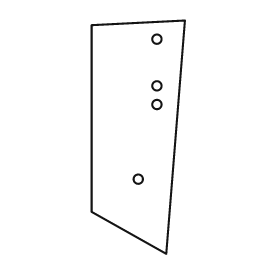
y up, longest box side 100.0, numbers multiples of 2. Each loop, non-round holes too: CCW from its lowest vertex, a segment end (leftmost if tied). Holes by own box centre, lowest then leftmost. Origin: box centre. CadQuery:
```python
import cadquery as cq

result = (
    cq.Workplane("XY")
    .moveTo(12.0, -50.0)
    .lineTo(20.0, 50.0)
    .lineTo(-20.0, 48.0)
    .lineTo(-20.0, -32.0)
    .close()
    .moveTo(0.0, -18.0)
    .circle(2.0)
    .moveTo(8.0, 14.0)
    .circle(2.0)
    .moveTo(8.0, 22.0)
    .circle(2.0)
    .moveTo(8.0, 42.0)
    .circle(2.0)
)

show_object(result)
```